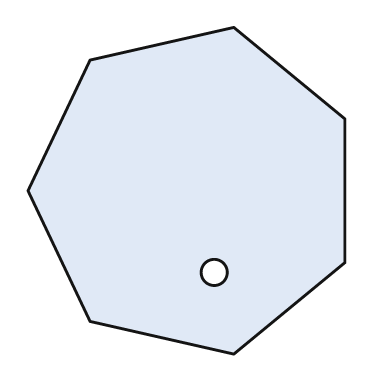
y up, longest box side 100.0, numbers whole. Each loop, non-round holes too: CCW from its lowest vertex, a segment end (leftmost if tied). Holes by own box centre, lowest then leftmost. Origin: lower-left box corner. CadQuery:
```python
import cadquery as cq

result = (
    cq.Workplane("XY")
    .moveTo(63.0, 0.0)
    .lineTo(97.0, 28.0)
    .lineTo(97.0, 72.0)
    .lineTo(63.0, 100.0)
    .lineTo(19.0, 90.0)
    .lineTo(0.0, 50.0)
    .lineTo(19.0, 10.0)
    .close()
    .moveTo(57.0, 25.0)
    .circle(4.0)
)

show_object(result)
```